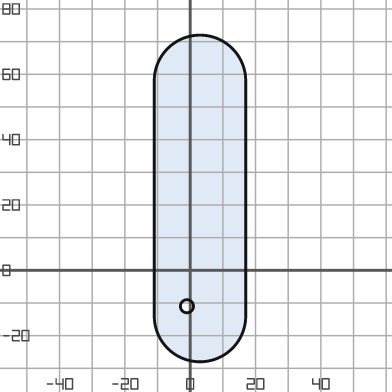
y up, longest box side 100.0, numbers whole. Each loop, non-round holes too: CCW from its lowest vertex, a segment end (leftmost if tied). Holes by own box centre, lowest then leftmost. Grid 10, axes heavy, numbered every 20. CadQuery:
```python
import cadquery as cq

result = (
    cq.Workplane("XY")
    .moveTo(-11.0, -14.0)
    .threePointArc((3.0, -28.0), (17.0, -14.0))
    .lineTo(17.0, 58.0)
    .threePointArc((3.0, 72.0), (-11.0, 58.0))
    .close()
    .moveTo(-1.0, -11.0)
    .circle(2.0)
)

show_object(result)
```